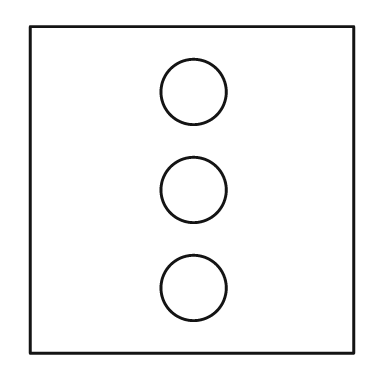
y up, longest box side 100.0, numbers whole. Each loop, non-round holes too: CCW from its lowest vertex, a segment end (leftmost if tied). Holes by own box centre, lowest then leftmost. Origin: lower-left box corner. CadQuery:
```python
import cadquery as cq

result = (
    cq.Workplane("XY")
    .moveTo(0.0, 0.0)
    .lineTo(99.0, 0.0)
    .lineTo(99.0, 100.0)
    .lineTo(0.0, 100.0)
    .close()
    .moveTo(50.0, 20.0)
    .circle(10.0)
    .moveTo(50.0, 50.0)
    .circle(10.0)
    .moveTo(50.0, 80.0)
    .circle(10.0)
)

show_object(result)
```